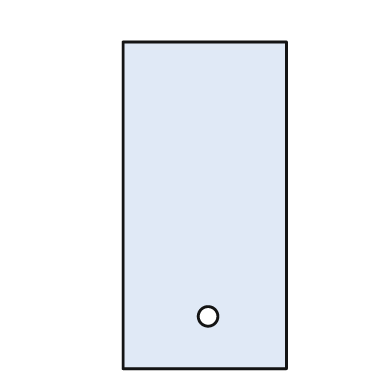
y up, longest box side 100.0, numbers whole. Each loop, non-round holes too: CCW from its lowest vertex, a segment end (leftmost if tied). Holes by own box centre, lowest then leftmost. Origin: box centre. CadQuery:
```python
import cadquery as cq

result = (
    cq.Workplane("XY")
    .moveTo(-25.0, -50.0)
    .lineTo(25.0, -50.0)
    .lineTo(25.0, 50.0)
    .lineTo(-25.0, 50.0)
    .close()
    .moveTo(1.0, -34.0)
    .circle(3.0)
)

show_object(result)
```